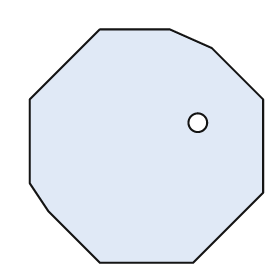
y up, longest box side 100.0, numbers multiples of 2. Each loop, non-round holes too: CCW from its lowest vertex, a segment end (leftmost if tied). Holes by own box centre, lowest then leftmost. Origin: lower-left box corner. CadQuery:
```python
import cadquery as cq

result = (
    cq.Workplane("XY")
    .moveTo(30.0, 0.0)
    .lineTo(70.0, 0.0)
    .lineTo(100.0, 30.0)
    .lineTo(100.0, 70.0)
    .lineTo(78.0, 92.0)
    .lineTo(60.0, 100.0)
    .lineTo(30.0, 100.0)
    .lineTo(0.0, 70.0)
    .lineTo(0.0, 34.0)
    .lineTo(8.0, 22.0)
    .close()
    .moveTo(72.0, 60.0)
    .circle(4.0)
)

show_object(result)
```